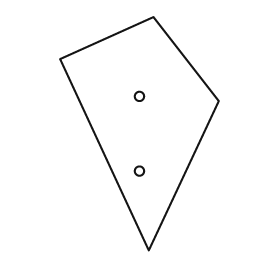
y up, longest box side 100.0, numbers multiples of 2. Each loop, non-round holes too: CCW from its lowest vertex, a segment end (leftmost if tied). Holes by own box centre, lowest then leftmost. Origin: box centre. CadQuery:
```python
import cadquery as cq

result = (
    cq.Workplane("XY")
    .moveTo(4.0, -50.0)
    .lineTo(34.0, 14.0)
    .lineTo(6.0, 50.0)
    .lineTo(-34.0, 32.0)
    .close()
    .moveTo(0.0, -16.0)
    .circle(2.0)
    .moveTo(0.0, 16.0)
    .circle(2.0)
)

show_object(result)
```